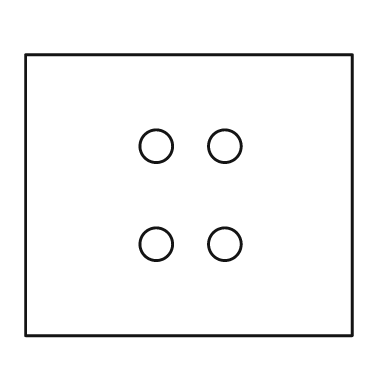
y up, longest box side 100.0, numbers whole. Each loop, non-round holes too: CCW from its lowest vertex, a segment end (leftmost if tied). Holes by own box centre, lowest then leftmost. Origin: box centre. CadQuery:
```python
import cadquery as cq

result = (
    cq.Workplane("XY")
    .moveTo(-50.0, -43.0)
    .lineTo(50.0, -43.0)
    .lineTo(50.0, 43.0)
    .lineTo(-50.0, 43.0)
    .close()
    .moveTo(-10.0, -15.0)
    .circle(5.0)
    .moveTo(11.0, -15.0)
    .circle(5.0)
    .moveTo(-10.0, 15.0)
    .circle(5.0)
    .moveTo(11.0, 15.0)
    .circle(5.0)
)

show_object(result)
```